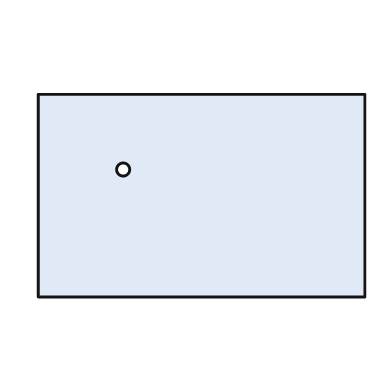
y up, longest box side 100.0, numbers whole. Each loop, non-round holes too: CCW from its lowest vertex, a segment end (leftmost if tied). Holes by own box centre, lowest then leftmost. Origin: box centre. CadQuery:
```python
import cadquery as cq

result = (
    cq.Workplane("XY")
    .moveTo(-50.0, -31.0)
    .lineTo(50.0, -31.0)
    .lineTo(50.0, 31.0)
    .lineTo(-50.0, 31.0)
    .close()
    .moveTo(-24.0, 8.0)
    .circle(2.0)
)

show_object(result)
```